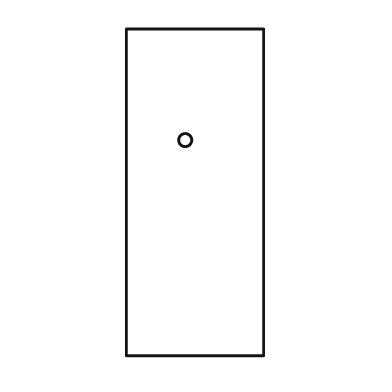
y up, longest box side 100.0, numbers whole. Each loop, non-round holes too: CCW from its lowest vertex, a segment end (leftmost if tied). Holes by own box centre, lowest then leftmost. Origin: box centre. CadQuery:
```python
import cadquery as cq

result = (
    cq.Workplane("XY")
    .moveTo(-21.0, -50.0)
    .lineTo(21.0, -50.0)
    .lineTo(21.0, 50.0)
    .lineTo(-21.0, 50.0)
    .close()
    .moveTo(-3.0, 16.0)
    .circle(2.0)
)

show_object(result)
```